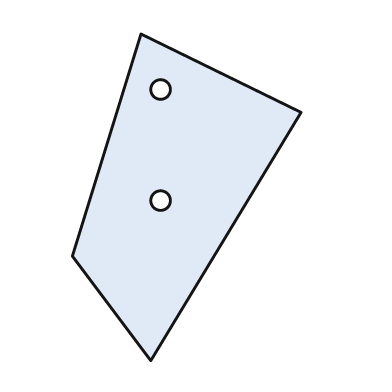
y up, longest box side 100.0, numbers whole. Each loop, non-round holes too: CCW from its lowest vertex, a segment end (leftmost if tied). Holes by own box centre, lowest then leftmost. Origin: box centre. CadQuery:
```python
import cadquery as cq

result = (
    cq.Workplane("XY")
    .moveTo(-11.0, -50.0)
    .lineTo(35.0, 26.0)
    .lineTo(-14.0, 50.0)
    .lineTo(-35.0, -18.0)
    .close()
    .moveTo(-8.0, -1.0)
    .circle(3.0)
    .moveTo(-8.0, 33.0)
    .circle(3.0)
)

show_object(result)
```